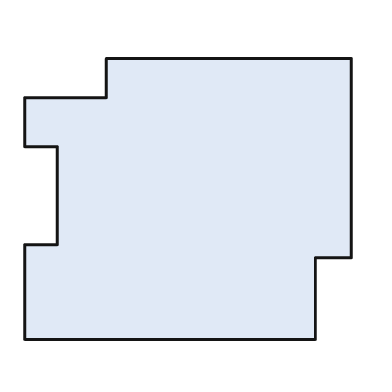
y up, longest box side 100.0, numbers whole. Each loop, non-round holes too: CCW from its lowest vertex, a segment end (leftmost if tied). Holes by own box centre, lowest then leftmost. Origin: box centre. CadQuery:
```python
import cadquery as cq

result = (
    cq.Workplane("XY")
    .moveTo(-50.0, -43.0)
    .lineTo(39.0, -43.0)
    .lineTo(39.0, -18.0)
    .lineTo(50.0, -18.0)
    .lineTo(50.0, 43.0)
    .lineTo(-25.0, 43.0)
    .lineTo(-25.0, 31.0)
    .lineTo(-50.0, 31.0)
    .lineTo(-50.0, 16.0)
    .lineTo(-40.0, 16.0)
    .lineTo(-40.0, -14.0)
    .lineTo(-50.0, -14.0)
    .close()
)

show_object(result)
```